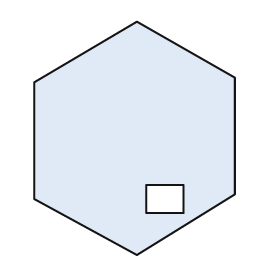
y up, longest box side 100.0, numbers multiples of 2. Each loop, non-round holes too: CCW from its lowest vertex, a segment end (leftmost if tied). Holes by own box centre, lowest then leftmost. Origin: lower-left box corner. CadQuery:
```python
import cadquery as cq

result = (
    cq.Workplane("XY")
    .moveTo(44.0, 0.0)
    .lineTo(86.0, 26.0)
    .lineTo(86.0, 76.0)
    .lineTo(44.0, 100.0)
    .lineTo(0.0, 74.0)
    .lineTo(0.0, 24.0)
    .close()
    .moveTo(48.0, 18.0)
    .lineTo(64.0, 18.0)
    .lineTo(64.0, 30.0)
    .lineTo(48.0, 30.0)
    .close()
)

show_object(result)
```